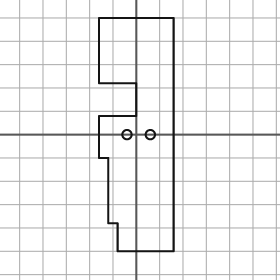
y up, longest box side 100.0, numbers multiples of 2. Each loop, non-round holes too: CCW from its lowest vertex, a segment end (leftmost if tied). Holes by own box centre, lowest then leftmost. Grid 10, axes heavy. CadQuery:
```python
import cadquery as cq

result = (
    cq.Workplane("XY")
    .moveTo(-8.0, -50.0)
    .lineTo(16.0, -50.0)
    .lineTo(16.0, 50.0)
    .lineTo(-16.0, 50.0)
    .lineTo(-16.0, 22.0)
    .lineTo(0.0, 22.0)
    .lineTo(0.0, 8.0)
    .lineTo(-16.0, 8.0)
    .lineTo(-16.0, -10.0)
    .lineTo(-12.0, -10.0)
    .lineTo(-12.0, -38.0)
    .lineTo(-8.0, -38.0)
    .close()
    .moveTo(-4.0, 0.0)
    .circle(2.0)
    .moveTo(6.0, 0.0)
    .circle(2.0)
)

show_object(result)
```